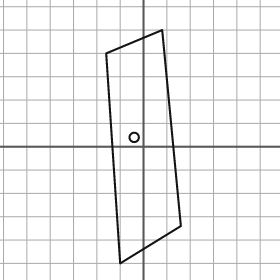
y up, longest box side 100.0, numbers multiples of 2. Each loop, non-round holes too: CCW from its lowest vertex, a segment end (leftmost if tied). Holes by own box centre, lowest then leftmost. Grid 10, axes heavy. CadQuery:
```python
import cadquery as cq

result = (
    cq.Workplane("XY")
    .moveTo(-10.0, -50.0)
    .lineTo(16.0, -34.0)
    .lineTo(8.0, 50.0)
    .lineTo(-16.0, 40.0)
    .close()
    .moveTo(-4.0, 4.0)
    .circle(2.0)
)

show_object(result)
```